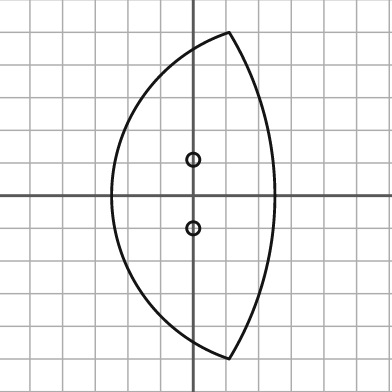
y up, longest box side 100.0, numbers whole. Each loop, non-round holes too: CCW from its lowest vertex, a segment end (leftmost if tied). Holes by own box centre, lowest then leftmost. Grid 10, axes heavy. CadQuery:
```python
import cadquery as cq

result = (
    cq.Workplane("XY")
    .moveTo(11.0, -50.0)
    .threePointArc((25.0, 0.0), (11.0, 50.0))
    .threePointArc((-25.0, 0.0), (11.0, -50.0))
    .close()
    .moveTo(0.0, -10.0)
    .circle(2.0)
    .moveTo(0.0, 11.0)
    .circle(2.0)
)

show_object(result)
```